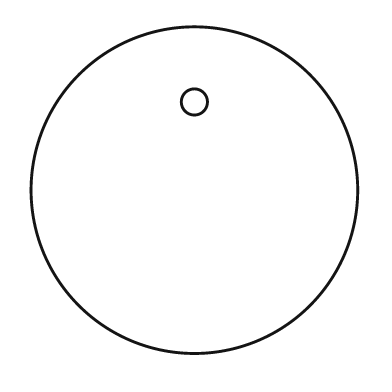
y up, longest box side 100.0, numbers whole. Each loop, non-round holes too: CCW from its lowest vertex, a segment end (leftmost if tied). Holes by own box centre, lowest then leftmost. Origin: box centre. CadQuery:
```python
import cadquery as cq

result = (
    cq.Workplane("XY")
    .moveTo(0.0, 0.0)
    .circle(50.0)
    .moveTo(0.0, 27.0)
    .circle(4.0)
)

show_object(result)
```